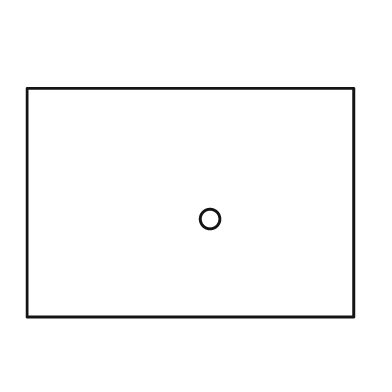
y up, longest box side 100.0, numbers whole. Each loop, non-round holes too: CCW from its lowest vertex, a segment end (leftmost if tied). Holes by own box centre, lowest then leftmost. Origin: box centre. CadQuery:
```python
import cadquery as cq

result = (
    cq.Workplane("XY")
    .moveTo(-50.0, -35.0)
    .lineTo(50.0, -35.0)
    .lineTo(50.0, 35.0)
    .lineTo(-50.0, 35.0)
    .close()
    .moveTo(6.0, -5.0)
    .circle(3.0)
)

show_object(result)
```